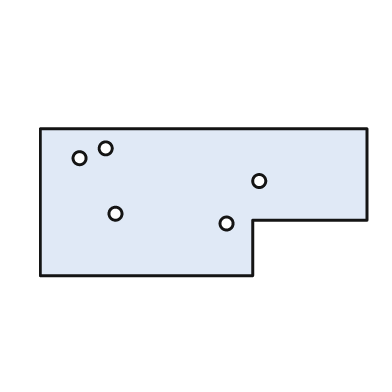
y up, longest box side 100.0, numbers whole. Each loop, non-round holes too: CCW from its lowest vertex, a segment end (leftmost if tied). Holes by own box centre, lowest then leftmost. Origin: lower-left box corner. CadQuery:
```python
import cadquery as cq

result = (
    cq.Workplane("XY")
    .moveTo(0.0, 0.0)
    .lineTo(65.0, 0.0)
    .lineTo(65.0, 17.0)
    .lineTo(100.0, 17.0)
    .lineTo(100.0, 45.0)
    .lineTo(0.0, 45.0)
    .close()
    .moveTo(57.0, 16.0)
    .circle(2.0)
    .moveTo(23.0, 19.0)
    .circle(2.0)
    .moveTo(67.0, 29.0)
    .circle(2.0)
    .moveTo(12.0, 36.0)
    .circle(2.0)
    .moveTo(20.0, 39.0)
    .circle(2.0)
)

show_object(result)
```